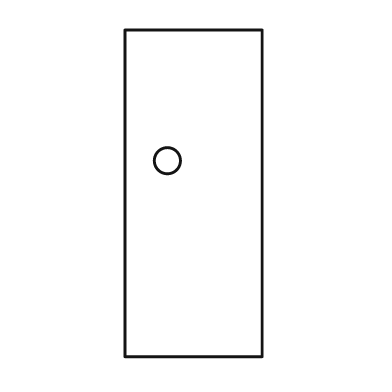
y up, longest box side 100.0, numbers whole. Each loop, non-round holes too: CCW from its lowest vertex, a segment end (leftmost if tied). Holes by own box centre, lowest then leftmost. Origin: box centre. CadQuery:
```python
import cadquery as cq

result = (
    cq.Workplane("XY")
    .moveTo(-21.0, -50.0)
    .lineTo(21.0, -50.0)
    .lineTo(21.0, 50.0)
    .lineTo(-21.0, 50.0)
    .close()
    .moveTo(-8.0, 10.0)
    .circle(4.0)
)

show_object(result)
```